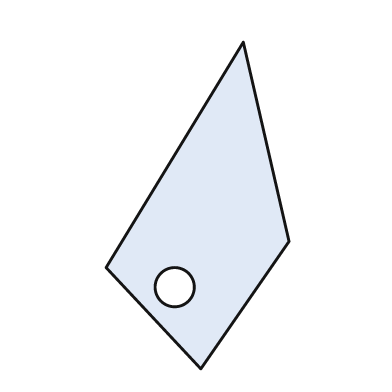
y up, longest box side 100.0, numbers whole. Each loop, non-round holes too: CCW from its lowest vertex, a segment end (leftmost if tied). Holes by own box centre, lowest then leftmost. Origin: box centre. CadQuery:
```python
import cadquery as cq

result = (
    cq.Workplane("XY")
    .moveTo(1.0, -50.0)
    .lineTo(28.0, -11.0)
    .lineTo(14.0, 50.0)
    .lineTo(-28.0, -19.0)
    .close()
    .moveTo(-7.0, -25.0)
    .circle(6.0)
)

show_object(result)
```